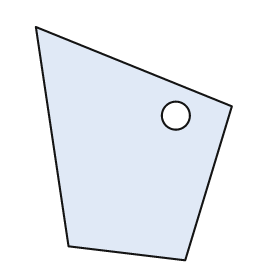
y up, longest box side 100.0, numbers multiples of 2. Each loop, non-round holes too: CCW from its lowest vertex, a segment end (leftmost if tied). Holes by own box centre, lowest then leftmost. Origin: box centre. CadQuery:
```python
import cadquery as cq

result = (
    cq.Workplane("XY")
    .moveTo(22.0, -50.0)
    .lineTo(42.0, 16.0)
    .lineTo(-42.0, 50.0)
    .lineTo(-28.0, -44.0)
    .close()
    .moveTo(18.0, 12.0)
    .circle(6.0)
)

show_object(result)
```